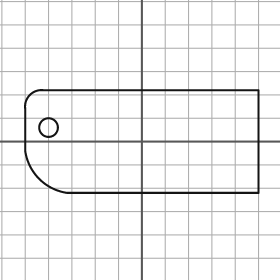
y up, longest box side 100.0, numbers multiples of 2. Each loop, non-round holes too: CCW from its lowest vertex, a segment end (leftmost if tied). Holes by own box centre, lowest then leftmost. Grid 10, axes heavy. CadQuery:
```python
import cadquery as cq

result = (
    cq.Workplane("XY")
    .moveTo(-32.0, -22.0)
    .lineTo(50.0, -22.0)
    .lineTo(50.0, 22.0)
    .lineTo(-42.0, 22.0)
    .threePointArc((-48.0, 20.0), (-50.0, 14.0))
    .lineTo(-50.0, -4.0)
    .threePointArc((-44.0, -16.0), (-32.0, -22.0))
    .close()
    .moveTo(-40.0, 6.0)
    .circle(4.0)
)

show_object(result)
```